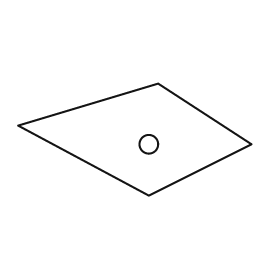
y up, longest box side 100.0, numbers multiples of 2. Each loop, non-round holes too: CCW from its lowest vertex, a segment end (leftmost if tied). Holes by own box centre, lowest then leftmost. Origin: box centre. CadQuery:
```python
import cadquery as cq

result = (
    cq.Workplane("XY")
    .moveTo(6.0, -24.0)
    .lineTo(50.0, -2.0)
    .lineTo(10.0, 24.0)
    .lineTo(-50.0, 6.0)
    .close()
    .moveTo(6.0, -2.0)
    .circle(4.0)
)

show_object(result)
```